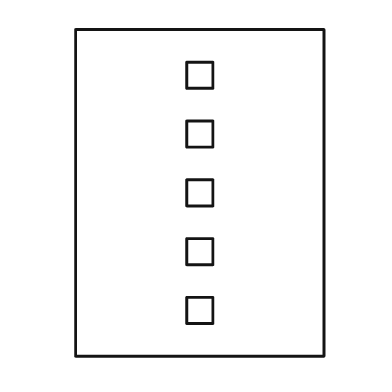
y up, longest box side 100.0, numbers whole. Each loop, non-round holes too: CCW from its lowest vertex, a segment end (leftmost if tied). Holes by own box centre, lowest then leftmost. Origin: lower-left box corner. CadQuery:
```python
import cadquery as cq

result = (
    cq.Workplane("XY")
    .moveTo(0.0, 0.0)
    .lineTo(76.0, 0.0)
    .lineTo(76.0, 100.0)
    .lineTo(0.0, 100.0)
    .close()
    .moveTo(34.0, 10.0)
    .lineTo(42.0, 10.0)
    .lineTo(42.0, 18.0)
    .lineTo(34.0, 18.0)
    .close()
    .moveTo(34.0, 28.0)
    .lineTo(42.0, 28.0)
    .lineTo(42.0, 36.0)
    .lineTo(34.0, 36.0)
    .close()
    .moveTo(34.0, 46.0)
    .lineTo(42.0, 46.0)
    .lineTo(42.0, 54.0)
    .lineTo(34.0, 54.0)
    .close()
    .moveTo(34.0, 64.0)
    .lineTo(42.0, 64.0)
    .lineTo(42.0, 72.0)
    .lineTo(34.0, 72.0)
    .close()
    .moveTo(34.0, 82.0)
    .lineTo(42.0, 82.0)
    .lineTo(42.0, 90.0)
    .lineTo(34.0, 90.0)
    .close()
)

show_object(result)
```